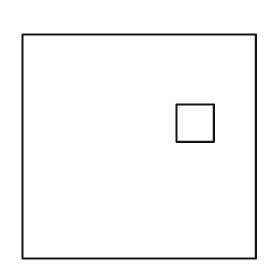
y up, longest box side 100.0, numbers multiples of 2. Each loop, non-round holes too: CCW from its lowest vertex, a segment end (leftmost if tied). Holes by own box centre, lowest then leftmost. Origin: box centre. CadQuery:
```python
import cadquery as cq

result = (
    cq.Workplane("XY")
    .moveTo(-50.0, -48.0)
    .lineTo(50.0, -48.0)
    .lineTo(50.0, 48.0)
    .lineTo(-50.0, 48.0)
    .close()
    .moveTo(16.0, 2.0)
    .lineTo(32.0, 2.0)
    .lineTo(32.0, 18.0)
    .lineTo(16.0, 18.0)
    .close()
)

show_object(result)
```